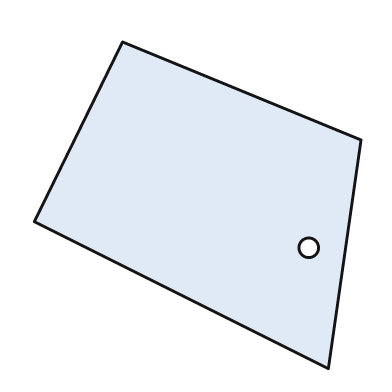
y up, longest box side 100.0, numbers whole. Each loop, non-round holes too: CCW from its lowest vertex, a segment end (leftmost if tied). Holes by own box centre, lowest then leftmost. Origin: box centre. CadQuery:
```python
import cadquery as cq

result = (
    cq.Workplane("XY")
    .moveTo(40.0, -50.0)
    .lineTo(50.0, 20.0)
    .lineTo(-23.0, 50.0)
    .lineTo(-50.0, -5.0)
    .close()
    .moveTo(34.0, -13.0)
    .circle(3.0)
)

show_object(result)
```